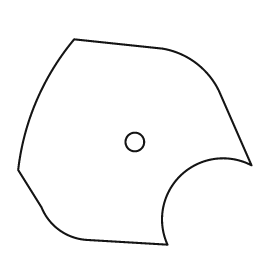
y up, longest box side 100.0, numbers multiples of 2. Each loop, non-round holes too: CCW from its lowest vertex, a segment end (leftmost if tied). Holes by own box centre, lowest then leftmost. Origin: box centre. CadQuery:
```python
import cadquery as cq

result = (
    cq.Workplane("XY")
    .moveTo(14.0, -44.0)
    .threePointArc((20.0, -14.0), (50.0, -10.0))
    .lineTo(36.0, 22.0)
    .threePointArc((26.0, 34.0), (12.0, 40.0))
    .lineTo(-26.0, 44.0)
    .threePointArc((-42.0, 18.0), (-50.0, -12.0))
    .lineTo(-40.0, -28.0)
    .threePointArc((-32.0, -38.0), (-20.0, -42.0))
    .close()
    .moveTo(0.0, 0.0)
    .circle(4.0)
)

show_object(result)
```